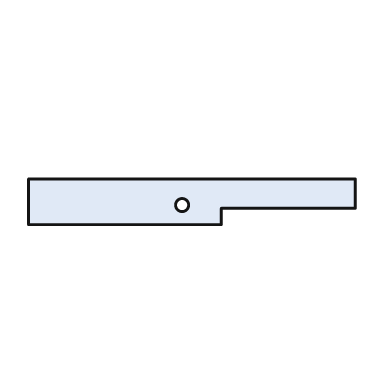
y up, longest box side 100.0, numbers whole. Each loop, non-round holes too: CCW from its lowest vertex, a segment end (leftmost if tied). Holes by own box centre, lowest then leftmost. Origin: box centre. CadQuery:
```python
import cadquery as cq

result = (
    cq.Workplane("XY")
    .moveTo(-50.0, -7.0)
    .lineTo(9.0, -7.0)
    .lineTo(9.0, -2.0)
    .lineTo(50.0, -2.0)
    .lineTo(50.0, 7.0)
    .lineTo(-50.0, 7.0)
    .close()
    .moveTo(-3.0, -1.0)
    .circle(2.0)
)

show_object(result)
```